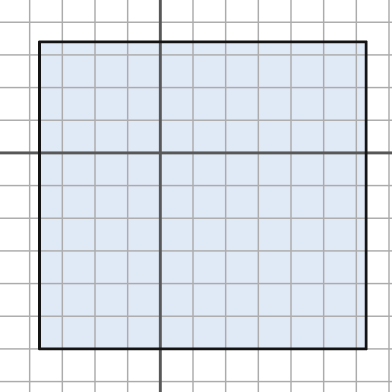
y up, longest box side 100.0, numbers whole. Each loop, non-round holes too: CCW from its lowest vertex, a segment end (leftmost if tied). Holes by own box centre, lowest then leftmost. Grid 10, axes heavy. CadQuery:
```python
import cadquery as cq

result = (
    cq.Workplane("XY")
    .moveTo(-37.0, -60.0)
    .lineTo(63.0, -60.0)
    .lineTo(63.0, 34.0)
    .lineTo(-37.0, 34.0)
    .close()
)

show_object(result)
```